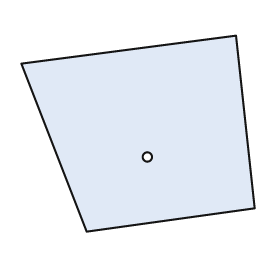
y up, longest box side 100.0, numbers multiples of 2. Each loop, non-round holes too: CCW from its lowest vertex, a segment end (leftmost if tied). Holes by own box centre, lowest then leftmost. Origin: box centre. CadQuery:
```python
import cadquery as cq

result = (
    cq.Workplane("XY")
    .moveTo(-22.0, -42.0)
    .lineTo(50.0, -32.0)
    .lineTo(42.0, 42.0)
    .lineTo(-50.0, 30.0)
    .close()
    .moveTo(4.0, -10.0)
    .circle(2.0)
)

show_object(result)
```